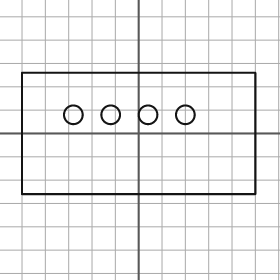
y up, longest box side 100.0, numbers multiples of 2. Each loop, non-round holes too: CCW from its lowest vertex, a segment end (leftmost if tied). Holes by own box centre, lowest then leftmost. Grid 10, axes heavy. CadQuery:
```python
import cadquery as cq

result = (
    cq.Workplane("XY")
    .moveTo(-50.0, -26.0)
    .lineTo(50.0, -26.0)
    .lineTo(50.0, 26.0)
    .lineTo(-50.0, 26.0)
    .close()
    .moveTo(-28.0, 8.0)
    .circle(4.0)
    .moveTo(-12.0, 8.0)
    .circle(4.0)
    .moveTo(4.0, 8.0)
    .circle(4.0)
    .moveTo(20.0, 8.0)
    .circle(4.0)
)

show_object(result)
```